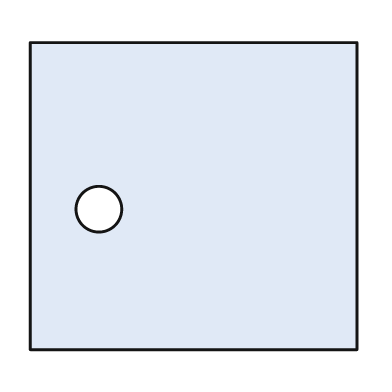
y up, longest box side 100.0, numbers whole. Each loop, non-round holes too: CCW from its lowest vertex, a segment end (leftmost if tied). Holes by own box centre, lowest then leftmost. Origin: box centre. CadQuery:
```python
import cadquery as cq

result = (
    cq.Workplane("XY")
    .moveTo(-50.0, -47.0)
    .lineTo(50.0, -47.0)
    .lineTo(50.0, 47.0)
    .lineTo(-50.0, 47.0)
    .close()
    .moveTo(-29.0, -4.0)
    .circle(7.0)
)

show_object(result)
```